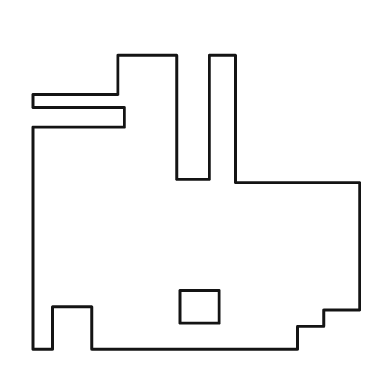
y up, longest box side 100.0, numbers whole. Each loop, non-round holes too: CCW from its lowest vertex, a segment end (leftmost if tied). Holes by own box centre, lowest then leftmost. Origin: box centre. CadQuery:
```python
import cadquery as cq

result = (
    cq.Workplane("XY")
    .moveTo(-50.0, -45.0)
    .lineTo(-44.0, -45.0)
    .lineTo(-44.0, -32.0)
    .lineTo(-32.0, -32.0)
    .lineTo(-32.0, -45.0)
    .lineTo(31.0, -45.0)
    .lineTo(31.0, -38.0)
    .lineTo(39.0, -38.0)
    .lineTo(39.0, -33.0)
    .lineTo(50.0, -33.0)
    .lineTo(50.0, 6.0)
    .lineTo(12.0, 6.0)
    .lineTo(12.0, 45.0)
    .lineTo(4.0, 45.0)
    .lineTo(4.0, 7.0)
    .lineTo(-6.0, 7.0)
    .lineTo(-6.0, 45.0)
    .lineTo(-24.0, 45.0)
    .lineTo(-24.0, 33.0)
    .lineTo(-50.0, 33.0)
    .lineTo(-50.0, 29.0)
    .lineTo(-22.0, 29.0)
    .lineTo(-22.0, 23.0)
    .lineTo(-50.0, 23.0)
    .close()
    .moveTo(-5.0, -37.0)
    .lineTo(7.0, -37.0)
    .lineTo(7.0, -27.0)
    .lineTo(-5.0, -27.0)
    .close()
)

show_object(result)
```